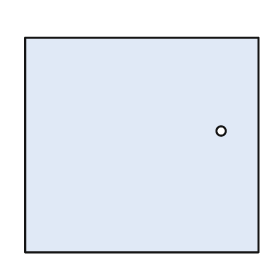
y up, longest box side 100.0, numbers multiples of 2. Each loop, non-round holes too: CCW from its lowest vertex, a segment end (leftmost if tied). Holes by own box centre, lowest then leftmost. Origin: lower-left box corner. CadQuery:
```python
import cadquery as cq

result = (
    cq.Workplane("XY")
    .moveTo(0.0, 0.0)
    .lineTo(100.0, 0.0)
    .lineTo(100.0, 92.0)
    .lineTo(0.0, 92.0)
    .close()
    .moveTo(84.0, 52.0)
    .circle(2.0)
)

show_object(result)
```